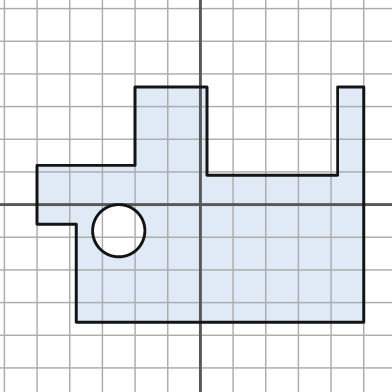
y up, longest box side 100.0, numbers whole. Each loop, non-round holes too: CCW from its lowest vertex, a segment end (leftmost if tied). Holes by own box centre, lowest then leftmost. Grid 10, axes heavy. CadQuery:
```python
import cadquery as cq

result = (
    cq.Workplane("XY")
    .moveTo(-38.0, -36.0)
    .lineTo(50.0, -36.0)
    .lineTo(50.0, 36.0)
    .lineTo(42.0, 36.0)
    .lineTo(42.0, 9.0)
    .lineTo(2.0, 9.0)
    .lineTo(2.0, 36.0)
    .lineTo(-20.0, 36.0)
    .lineTo(-20.0, 12.0)
    .lineTo(-50.0, 12.0)
    .lineTo(-50.0, -6.0)
    .lineTo(-38.0, -6.0)
    .close()
    .moveTo(-25.0, -8.0)
    .circle(8.0)
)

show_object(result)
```